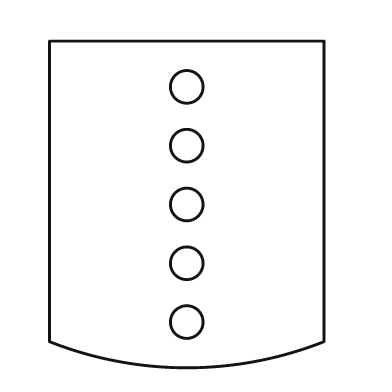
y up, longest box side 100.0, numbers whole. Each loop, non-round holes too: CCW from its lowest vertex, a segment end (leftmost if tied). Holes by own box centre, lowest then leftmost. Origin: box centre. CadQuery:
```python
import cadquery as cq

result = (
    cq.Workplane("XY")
    .moveTo(-42.0, -42.0)
    .threePointArc((0.0, -50.0), (42.0, -42.0))
    .lineTo(42.0, 50.0)
    .lineTo(-42.0, 50.0)
    .close()
    .moveTo(0.0, -36.0)
    .circle(5.0)
    .moveTo(0.0, -18.0)
    .circle(5.0)
    .moveTo(0.0, 0.0)
    .circle(5.0)
    .moveTo(0.0, 18.0)
    .circle(5.0)
    .moveTo(0.0, 36.0)
    .circle(5.0)
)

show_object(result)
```